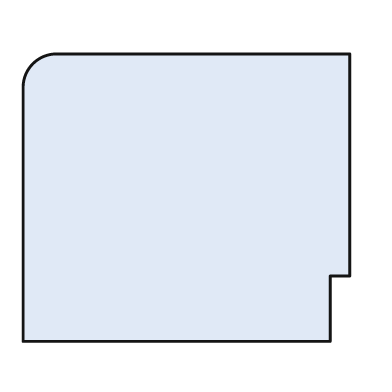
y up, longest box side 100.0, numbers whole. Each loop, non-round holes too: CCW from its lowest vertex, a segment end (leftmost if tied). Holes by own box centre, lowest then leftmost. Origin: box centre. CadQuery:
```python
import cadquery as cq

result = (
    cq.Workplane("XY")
    .moveTo(-50.0, -44.0)
    .lineTo(44.0, -44.0)
    .lineTo(44.0, -24.0)
    .lineTo(50.0, -24.0)
    .lineTo(50.0, 44.0)
    .lineTo(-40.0, 44.0)
    .threePointArc((-47.0, 41.0), (-50.0, 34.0))
    .close()
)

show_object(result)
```